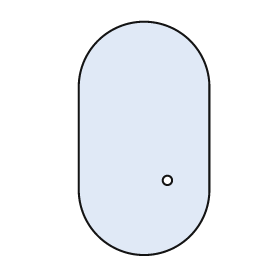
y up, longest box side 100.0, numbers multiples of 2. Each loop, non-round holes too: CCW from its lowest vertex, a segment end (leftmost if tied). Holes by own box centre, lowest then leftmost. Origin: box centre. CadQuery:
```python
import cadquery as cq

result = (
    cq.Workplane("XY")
    .moveTo(-28.0, -22.0)
    .threePointArc((0.0, -50.0), (28.0, -22.0))
    .lineTo(28.0, 22.0)
    .threePointArc((0.0, 50.0), (-28.0, 22.0))
    .close()
    .moveTo(10.0, -18.0)
    .circle(2.0)
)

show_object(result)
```